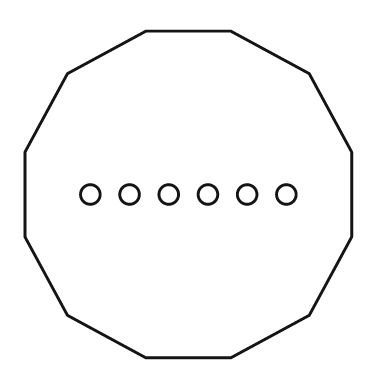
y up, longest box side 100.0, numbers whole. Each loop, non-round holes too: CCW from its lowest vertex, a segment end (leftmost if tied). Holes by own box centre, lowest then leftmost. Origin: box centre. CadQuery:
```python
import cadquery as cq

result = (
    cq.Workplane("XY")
    .moveTo(-13.0, -50.0)
    .lineTo(13.0, -50.0)
    .lineTo(37.0, -37.0)
    .lineTo(50.0, -13.0)
    .lineTo(50.0, 13.0)
    .lineTo(37.0, 37.0)
    .lineTo(13.0, 50.0)
    .lineTo(-13.0, 50.0)
    .lineTo(-37.0, 37.0)
    .lineTo(-50.0, 13.0)
    .lineTo(-50.0, -13.0)
    .lineTo(-37.0, -37.0)
    .close()
    .moveTo(-30.0, 0.0)
    .circle(3.0)
    .moveTo(-18.0, 0.0)
    .circle(3.0)
    .moveTo(-6.0, 0.0)
    .circle(3.0)
    .moveTo(6.0, 0.0)
    .circle(3.0)
    .moveTo(18.0, 0.0)
    .circle(3.0)
    .moveTo(30.0, 0.0)
    .circle(3.0)
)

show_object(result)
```